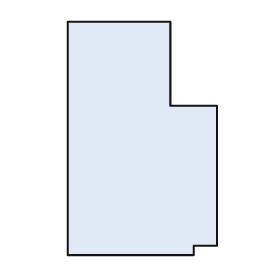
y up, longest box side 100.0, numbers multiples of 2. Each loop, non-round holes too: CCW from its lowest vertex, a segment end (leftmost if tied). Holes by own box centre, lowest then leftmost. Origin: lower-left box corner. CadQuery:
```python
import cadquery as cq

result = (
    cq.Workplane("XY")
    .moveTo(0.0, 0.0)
    .lineTo(54.0, 0.0)
    .lineTo(54.0, 4.0)
    .lineTo(64.0, 4.0)
    .lineTo(64.0, 64.0)
    .lineTo(44.0, 64.0)
    .lineTo(44.0, 100.0)
    .lineTo(0.0, 100.0)
    .close()
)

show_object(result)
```